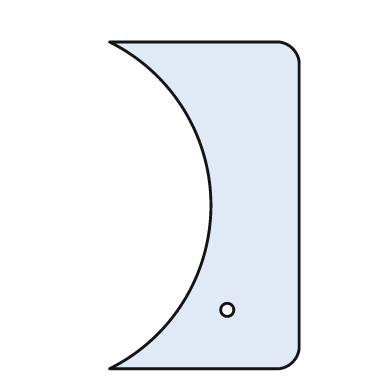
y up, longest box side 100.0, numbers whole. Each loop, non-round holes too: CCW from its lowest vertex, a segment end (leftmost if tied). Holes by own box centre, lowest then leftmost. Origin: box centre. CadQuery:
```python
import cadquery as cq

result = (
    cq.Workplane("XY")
    .moveTo(-29.0, -50.0)
    .lineTo(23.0, -50.0)
    .threePointArc((27.0, -48.0), (29.0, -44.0))
    .lineTo(29.0, 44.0)
    .threePointArc((27.0, 48.0), (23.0, 50.0))
    .lineTo(-29.0, 50.0)
    .threePointArc((2.0, 0.0), (-29.0, -50.0))
    .close()
    .moveTo(7.0, -32.0)
    .circle(2.0)
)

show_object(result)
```